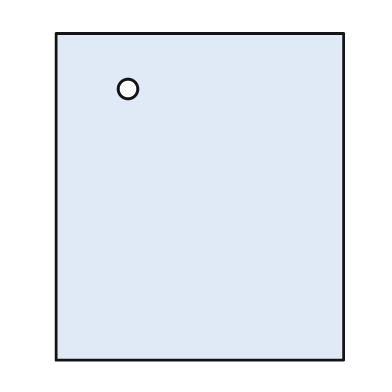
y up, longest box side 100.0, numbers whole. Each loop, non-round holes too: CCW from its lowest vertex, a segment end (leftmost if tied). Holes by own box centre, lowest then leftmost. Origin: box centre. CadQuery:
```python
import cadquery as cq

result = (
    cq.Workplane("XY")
    .moveTo(-44.0, -50.0)
    .lineTo(44.0, -50.0)
    .lineTo(44.0, 50.0)
    .lineTo(-44.0, 50.0)
    .close()
    .moveTo(-22.0, 33.0)
    .circle(3.0)
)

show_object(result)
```